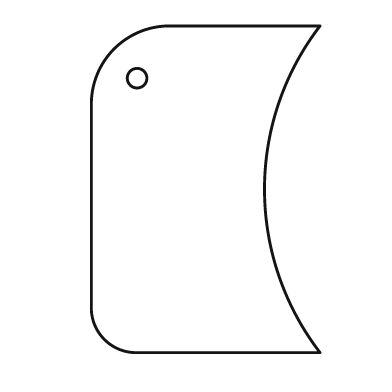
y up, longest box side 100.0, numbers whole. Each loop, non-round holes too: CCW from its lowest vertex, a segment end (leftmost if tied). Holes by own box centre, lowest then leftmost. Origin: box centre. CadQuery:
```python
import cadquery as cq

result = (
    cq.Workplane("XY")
    .moveTo(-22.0, -50.0)
    .lineTo(35.0, -50.0)
    .threePointArc((18.0, 0.0), (35.0, 50.0))
    .lineTo(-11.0, 50.0)
    .threePointArc((-28.0, 43.0), (-35.0, 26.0))
    .lineTo(-35.0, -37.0)
    .threePointArc((-31.0, -46.0), (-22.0, -50.0))
    .close()
    .moveTo(-21.0, 34.0)
    .circle(3.0)
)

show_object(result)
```